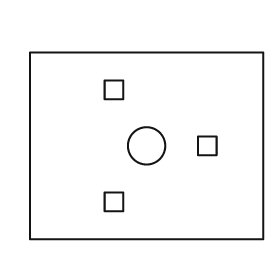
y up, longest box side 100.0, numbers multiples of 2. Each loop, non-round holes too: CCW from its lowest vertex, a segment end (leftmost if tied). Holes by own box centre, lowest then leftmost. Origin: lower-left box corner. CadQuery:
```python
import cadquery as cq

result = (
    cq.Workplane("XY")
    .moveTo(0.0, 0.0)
    .lineTo(100.0, 0.0)
    .lineTo(100.0, 80.0)
    .lineTo(0.0, 80.0)
    .close()
    .moveTo(32.0, 12.0)
    .lineTo(40.0, 12.0)
    .lineTo(40.0, 20.0)
    .lineTo(32.0, 20.0)
    .close()
    .moveTo(50.0, 40.0)
    .circle(8.0)
    .moveTo(72.0, 36.0)
    .lineTo(80.0, 36.0)
    .lineTo(80.0, 44.0)
    .lineTo(72.0, 44.0)
    .close()
    .moveTo(32.0, 60.0)
    .lineTo(40.0, 60.0)
    .lineTo(40.0, 68.0)
    .lineTo(32.0, 68.0)
    .close()
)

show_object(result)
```